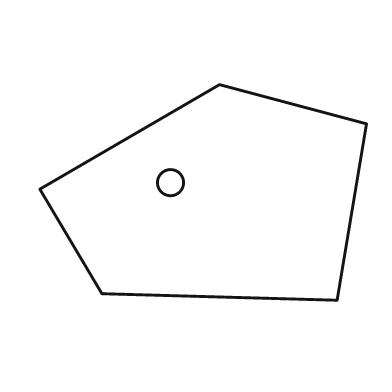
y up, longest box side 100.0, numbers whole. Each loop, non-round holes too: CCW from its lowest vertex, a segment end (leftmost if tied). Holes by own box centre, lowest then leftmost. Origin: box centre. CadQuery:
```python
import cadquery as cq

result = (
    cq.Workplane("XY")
    .moveTo(41.0, -33.0)
    .lineTo(50.0, 21.0)
    .lineTo(5.0, 33.0)
    .lineTo(-50.0, 1.0)
    .lineTo(-31.0, -31.0)
    .close()
    .moveTo(-10.0, 3.0)
    .circle(4.0)
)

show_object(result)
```